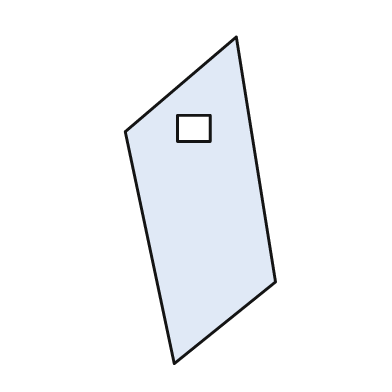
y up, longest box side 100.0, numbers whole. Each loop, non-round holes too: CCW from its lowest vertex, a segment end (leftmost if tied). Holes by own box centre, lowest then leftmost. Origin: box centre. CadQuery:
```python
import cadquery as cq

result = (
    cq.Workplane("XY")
    .moveTo(-8.0, -50.0)
    .lineTo(23.0, -25.0)
    .lineTo(11.0, 50.0)
    .lineTo(-23.0, 21.0)
    .close()
    .moveTo(-7.0, 18.0)
    .lineTo(3.0, 18.0)
    .lineTo(3.0, 26.0)
    .lineTo(-7.0, 26.0)
    .close()
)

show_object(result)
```